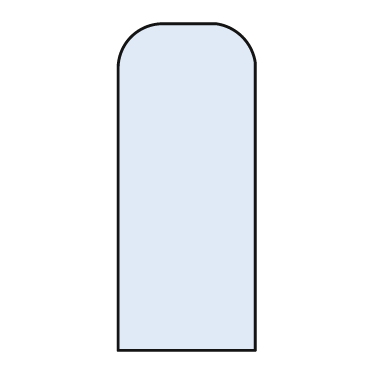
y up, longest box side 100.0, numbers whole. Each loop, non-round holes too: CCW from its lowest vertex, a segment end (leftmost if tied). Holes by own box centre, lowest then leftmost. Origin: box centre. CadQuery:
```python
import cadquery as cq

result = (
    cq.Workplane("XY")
    .moveTo(-21.0, -50.0)
    .lineTo(21.0, -50.0)
    .lineTo(21.0, 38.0)
    .threePointArc((17.0, 46.0), (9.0, 50.0))
    .lineTo(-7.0, 50.0)
    .threePointArc((-17.0, 46.0), (-21.0, 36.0))
    .close()
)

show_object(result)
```